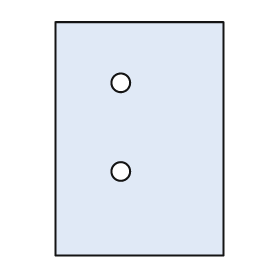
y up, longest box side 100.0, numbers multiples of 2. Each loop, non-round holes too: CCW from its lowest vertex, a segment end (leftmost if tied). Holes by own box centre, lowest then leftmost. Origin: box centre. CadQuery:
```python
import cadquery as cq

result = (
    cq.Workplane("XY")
    .moveTo(-36.0, -50.0)
    .lineTo(36.0, -50.0)
    .lineTo(36.0, 50.0)
    .lineTo(-36.0, 50.0)
    .close()
    .moveTo(-8.0, -14.0)
    .circle(4.0)
    .moveTo(-8.0, 24.0)
    .circle(4.0)
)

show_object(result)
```